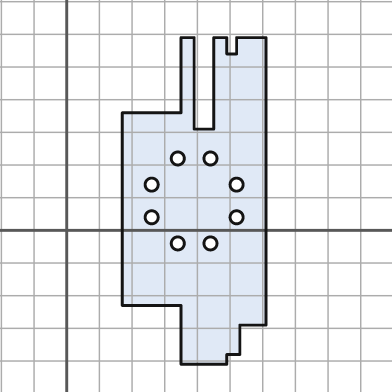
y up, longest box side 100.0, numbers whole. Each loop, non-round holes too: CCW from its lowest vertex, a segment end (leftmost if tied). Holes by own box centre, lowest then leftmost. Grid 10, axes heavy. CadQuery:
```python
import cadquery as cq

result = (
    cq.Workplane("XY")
    .moveTo(35.0, -41.0)
    .lineTo(49.0, -41.0)
    .lineTo(49.0, -38.0)
    .lineTo(53.0, -38.0)
    .lineTo(53.0, -29.0)
    .lineTo(61.0, -29.0)
    .lineTo(61.0, 59.0)
    .lineTo(52.0, 59.0)
    .lineTo(52.0, 54.0)
    .lineTo(49.0, 54.0)
    .lineTo(49.0, 59.0)
    .lineTo(45.0, 59.0)
    .lineTo(45.0, 31.0)
    .lineTo(39.0, 31.0)
    .lineTo(39.0, 59.0)
    .lineTo(35.0, 59.0)
    .lineTo(35.0, 36.0)
    .lineTo(17.0, 36.0)
    .lineTo(17.0, -23.0)
    .lineTo(35.0, -23.0)
    .close()
    .moveTo(34.0, -4.0)
    .circle(2.0)
    .moveTo(44.0, -4.0)
    .circle(2.0)
    .moveTo(26.0, 4.0)
    .circle(2.0)
    .moveTo(52.0, 4.0)
    .circle(2.0)
    .moveTo(26.0, 14.0)
    .circle(2.0)
    .moveTo(52.0, 14.0)
    .circle(2.0)
    .moveTo(34.0, 22.0)
    .circle(2.0)
    .moveTo(44.0, 22.0)
    .circle(2.0)
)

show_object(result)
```